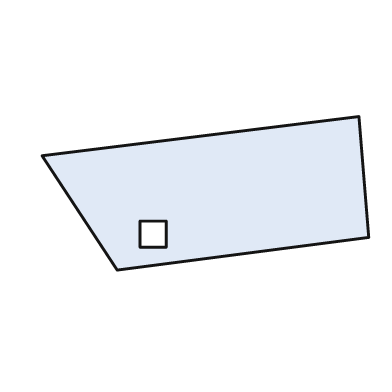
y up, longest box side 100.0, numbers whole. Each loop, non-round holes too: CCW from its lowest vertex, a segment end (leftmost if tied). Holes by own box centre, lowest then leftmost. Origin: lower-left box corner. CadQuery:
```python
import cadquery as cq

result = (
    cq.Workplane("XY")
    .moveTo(23.0, 0.0)
    .lineTo(100.0, 10.0)
    .lineTo(97.0, 47.0)
    .lineTo(0.0, 35.0)
    .close()
    .moveTo(30.0, 7.0)
    .lineTo(38.0, 7.0)
    .lineTo(38.0, 15.0)
    .lineTo(30.0, 15.0)
    .close()
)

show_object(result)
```